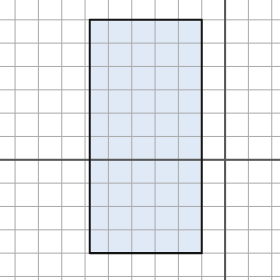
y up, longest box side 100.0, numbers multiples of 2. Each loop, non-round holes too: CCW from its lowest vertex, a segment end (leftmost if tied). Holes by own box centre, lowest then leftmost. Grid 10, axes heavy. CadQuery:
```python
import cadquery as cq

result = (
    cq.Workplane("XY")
    .moveTo(-58.0, -40.0)
    .lineTo(-10.0, -40.0)
    .lineTo(-10.0, 60.0)
    .lineTo(-58.0, 60.0)
    .close()
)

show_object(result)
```